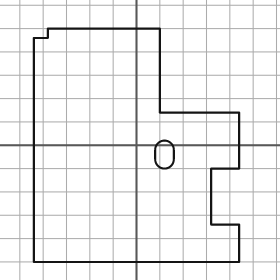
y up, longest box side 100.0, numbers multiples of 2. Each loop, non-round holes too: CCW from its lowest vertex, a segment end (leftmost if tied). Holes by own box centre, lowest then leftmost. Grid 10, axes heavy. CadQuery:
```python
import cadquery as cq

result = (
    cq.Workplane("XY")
    .moveTo(-44.0, -50.0)
    .lineTo(44.0, -50.0)
    .lineTo(44.0, -34.0)
    .lineTo(32.0, -34.0)
    .lineTo(32.0, -10.0)
    .lineTo(44.0, -10.0)
    .lineTo(44.0, 14.0)
    .lineTo(10.0, 14.0)
    .lineTo(10.0, 50.0)
    .lineTo(-38.0, 50.0)
    .lineTo(-38.0, 46.0)
    .lineTo(-44.0, 46.0)
    .close()
    .moveTo(8.0, -6.0)
    .threePointArc((12.0, -10.0), (16.0, -6.0))
    .lineTo(16.0, -2.0)
    .threePointArc((12.0, 2.0), (8.0, -2.0))
    .close()
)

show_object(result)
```